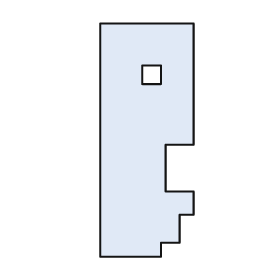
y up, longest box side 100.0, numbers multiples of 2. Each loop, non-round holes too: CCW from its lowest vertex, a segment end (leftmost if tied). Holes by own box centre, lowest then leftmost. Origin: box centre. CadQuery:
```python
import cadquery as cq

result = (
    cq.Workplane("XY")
    .moveTo(-20.0, -50.0)
    .lineTo(6.0, -50.0)
    .lineTo(6.0, -44.0)
    .lineTo(14.0, -44.0)
    .lineTo(14.0, -32.0)
    .lineTo(20.0, -32.0)
    .lineTo(20.0, -22.0)
    .lineTo(8.0, -22.0)
    .lineTo(8.0, -2.0)
    .lineTo(20.0, -2.0)
    .lineTo(20.0, 50.0)
    .lineTo(-20.0, 50.0)
    .close()
    .moveTo(-2.0, 24.0)
    .lineTo(6.0, 24.0)
    .lineTo(6.0, 32.0)
    .lineTo(-2.0, 32.0)
    .close()
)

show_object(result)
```